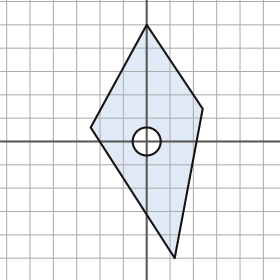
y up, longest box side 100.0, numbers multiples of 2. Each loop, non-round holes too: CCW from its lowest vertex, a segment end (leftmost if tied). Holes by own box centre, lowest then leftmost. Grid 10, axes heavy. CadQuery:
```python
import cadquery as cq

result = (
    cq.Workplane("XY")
    .moveTo(12.0, -50.0)
    .lineTo(24.0, 14.0)
    .lineTo(0.0, 50.0)
    .lineTo(-24.0, 6.0)
    .close()
    .moveTo(0.0, 0.0)
    .circle(6.0)
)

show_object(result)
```